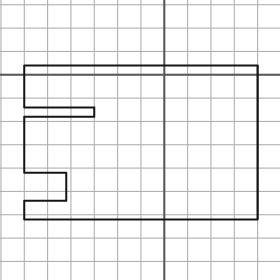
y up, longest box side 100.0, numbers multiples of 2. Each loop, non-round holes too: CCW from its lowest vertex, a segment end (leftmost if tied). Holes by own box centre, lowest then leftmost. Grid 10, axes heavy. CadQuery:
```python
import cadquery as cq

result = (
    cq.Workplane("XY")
    .moveTo(-60.0, -62.0)
    .lineTo(40.0, -62.0)
    .lineTo(40.0, 4.0)
    .lineTo(-60.0, 4.0)
    .lineTo(-60.0, -14.0)
    .lineTo(-30.0, -14.0)
    .lineTo(-30.0, -18.0)
    .lineTo(-60.0, -18.0)
    .lineTo(-60.0, -42.0)
    .lineTo(-42.0, -42.0)
    .lineTo(-42.0, -54.0)
    .lineTo(-60.0, -54.0)
    .close()
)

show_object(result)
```